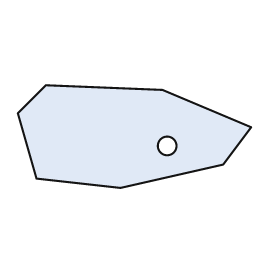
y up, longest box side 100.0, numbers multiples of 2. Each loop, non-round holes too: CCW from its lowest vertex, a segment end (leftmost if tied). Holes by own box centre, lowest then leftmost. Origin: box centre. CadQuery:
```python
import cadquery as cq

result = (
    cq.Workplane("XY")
    .moveTo(-6.0, -22.0)
    .lineTo(38.0, -12.0)
    .lineTo(50.0, 4.0)
    .lineTo(12.0, 20.0)
    .lineTo(-38.0, 22.0)
    .lineTo(-50.0, 10.0)
    .lineTo(-42.0, -18.0)
    .close()
    .moveTo(14.0, -4.0)
    .circle(4.0)
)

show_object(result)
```